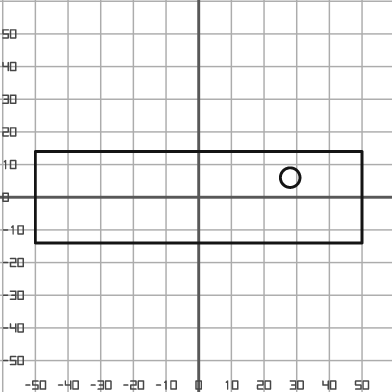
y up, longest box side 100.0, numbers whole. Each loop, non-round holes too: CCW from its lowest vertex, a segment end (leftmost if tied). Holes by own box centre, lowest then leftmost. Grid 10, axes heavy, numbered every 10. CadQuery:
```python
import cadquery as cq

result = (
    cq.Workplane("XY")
    .moveTo(-50.0, -14.0)
    .lineTo(50.0, -14.0)
    .lineTo(50.0, 14.0)
    .lineTo(-50.0, 14.0)
    .close()
    .moveTo(28.0, 6.0)
    .circle(3.0)
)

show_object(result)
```